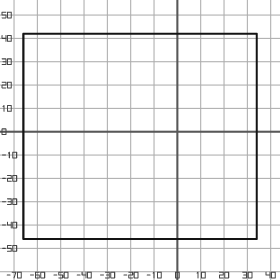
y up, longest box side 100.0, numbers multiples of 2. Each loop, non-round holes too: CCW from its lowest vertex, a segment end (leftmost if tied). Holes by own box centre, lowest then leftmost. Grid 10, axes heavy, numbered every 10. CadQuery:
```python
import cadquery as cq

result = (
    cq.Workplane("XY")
    .moveTo(-66.0, -46.0)
    .lineTo(34.0, -46.0)
    .lineTo(34.0, 42.0)
    .lineTo(-66.0, 42.0)
    .close()
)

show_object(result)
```